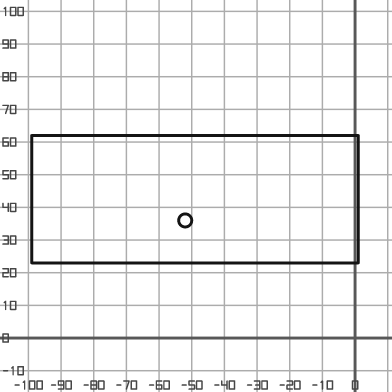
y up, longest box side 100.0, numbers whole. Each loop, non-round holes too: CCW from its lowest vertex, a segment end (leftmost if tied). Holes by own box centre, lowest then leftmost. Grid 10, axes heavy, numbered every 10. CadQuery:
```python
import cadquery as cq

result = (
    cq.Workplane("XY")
    .moveTo(-99.0, 23.0)
    .lineTo(1.0, 23.0)
    .lineTo(1.0, 62.0)
    .lineTo(-99.0, 62.0)
    .close()
    .moveTo(-52.0, 36.0)
    .circle(2.0)
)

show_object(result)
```